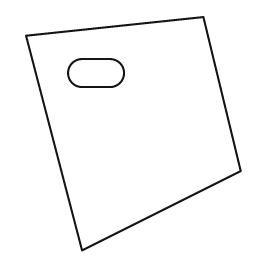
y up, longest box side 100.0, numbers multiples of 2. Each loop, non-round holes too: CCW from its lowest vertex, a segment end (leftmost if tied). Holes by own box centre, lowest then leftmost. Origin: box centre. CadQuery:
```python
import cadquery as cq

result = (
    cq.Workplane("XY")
    .moveTo(-22.0, -50.0)
    .lineTo(46.0, -16.0)
    .lineTo(30.0, 50.0)
    .lineTo(-46.0, 42.0)
    .close()
    .moveTo(-22.0, 20.0)
    .lineTo(-10.0, 20.0)
    .threePointArc((-4.0, 26.0), (-10.0, 32.0))
    .lineTo(-22.0, 32.0)
    .threePointArc((-28.0, 26.0), (-22.0, 20.0))
    .close()
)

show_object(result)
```